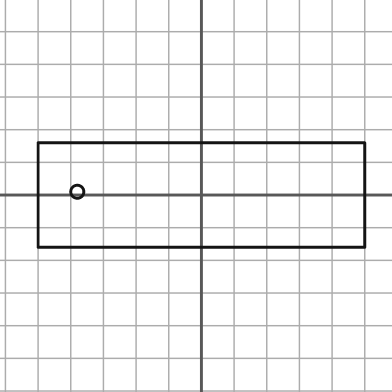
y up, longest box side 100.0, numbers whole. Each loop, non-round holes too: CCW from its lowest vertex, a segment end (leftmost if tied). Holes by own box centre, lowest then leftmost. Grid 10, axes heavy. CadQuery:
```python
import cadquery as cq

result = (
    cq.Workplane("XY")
    .moveTo(-50.0, -16.0)
    .lineTo(50.0, -16.0)
    .lineTo(50.0, 16.0)
    .lineTo(-50.0, 16.0)
    .close()
    .moveTo(-38.0, 1.0)
    .circle(2.0)
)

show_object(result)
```